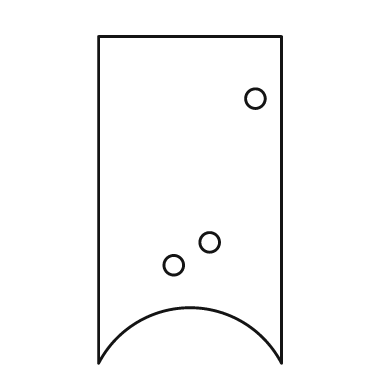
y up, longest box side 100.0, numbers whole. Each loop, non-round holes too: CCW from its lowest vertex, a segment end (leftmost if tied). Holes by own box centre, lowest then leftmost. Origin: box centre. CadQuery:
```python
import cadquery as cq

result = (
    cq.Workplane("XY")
    .moveTo(-28.0, -50.0)
    .threePointArc((0.0, -33.0), (28.0, -50.0))
    .lineTo(28.0, 50.0)
    .lineTo(-28.0, 50.0)
    .close()
    .moveTo(-5.0, -20.0)
    .circle(3.0)
    .moveTo(6.0, -13.0)
    .circle(3.0)
    .moveTo(20.0, 31.0)
    .circle(3.0)
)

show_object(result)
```